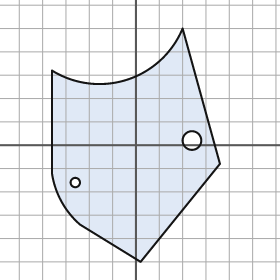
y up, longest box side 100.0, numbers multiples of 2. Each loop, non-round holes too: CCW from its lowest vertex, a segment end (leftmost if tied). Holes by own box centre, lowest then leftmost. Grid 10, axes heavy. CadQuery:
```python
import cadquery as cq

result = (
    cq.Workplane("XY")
    .moveTo(2.0, -50.0)
    .lineTo(36.0, -8.0)
    .lineTo(20.0, 50.0)
    .threePointArc((-4.0, 28.0), (-36.0, 32.0))
    .lineTo(-36.0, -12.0)
    .threePointArc((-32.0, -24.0), (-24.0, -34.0))
    .close()
    .moveTo(-26.0, -16.0)
    .circle(2.0)
    .moveTo(24.0, 2.0)
    .circle(4.0)
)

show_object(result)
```